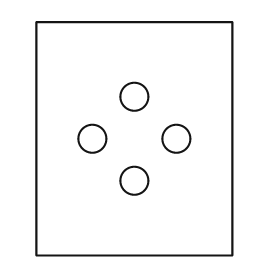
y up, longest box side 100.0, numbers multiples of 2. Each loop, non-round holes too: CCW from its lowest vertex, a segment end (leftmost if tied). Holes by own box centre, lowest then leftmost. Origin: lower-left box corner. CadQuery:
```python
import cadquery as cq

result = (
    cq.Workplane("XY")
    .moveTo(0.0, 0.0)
    .lineTo(84.0, 0.0)
    .lineTo(84.0, 100.0)
    .lineTo(0.0, 100.0)
    .close()
    .moveTo(42.0, 32.0)
    .circle(6.0)
    .moveTo(24.0, 50.0)
    .circle(6.0)
    .moveTo(60.0, 50.0)
    .circle(6.0)
    .moveTo(42.0, 68.0)
    .circle(6.0)
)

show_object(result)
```